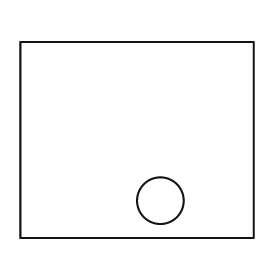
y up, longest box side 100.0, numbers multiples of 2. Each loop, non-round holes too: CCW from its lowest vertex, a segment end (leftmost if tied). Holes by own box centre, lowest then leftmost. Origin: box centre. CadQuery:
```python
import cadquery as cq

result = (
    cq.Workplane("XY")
    .moveTo(-50.0, -42.0)
    .lineTo(50.0, -42.0)
    .lineTo(50.0, 42.0)
    .lineTo(-50.0, 42.0)
    .close()
    .moveTo(10.0, -26.0)
    .circle(10.0)
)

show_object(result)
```